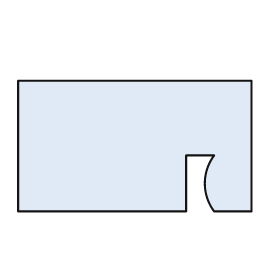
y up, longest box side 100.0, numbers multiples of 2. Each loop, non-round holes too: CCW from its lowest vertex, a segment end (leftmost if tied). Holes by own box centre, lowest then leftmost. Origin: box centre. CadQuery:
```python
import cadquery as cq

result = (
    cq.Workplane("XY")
    .moveTo(-50.0, -28.0)
    .lineTo(22.0, -28.0)
    .lineTo(22.0, -4.0)
    .lineTo(34.0, -4.0)
    .threePointArc((30.0, -16.0), (34.0, -28.0))
    .lineTo(50.0, -28.0)
    .lineTo(50.0, 28.0)
    .lineTo(-50.0, 28.0)
    .close()
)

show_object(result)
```